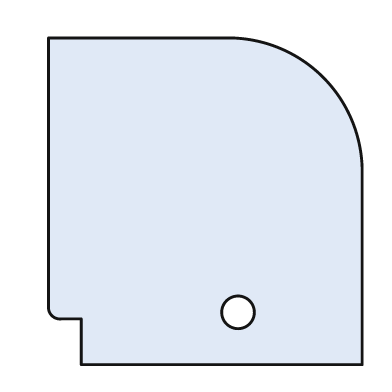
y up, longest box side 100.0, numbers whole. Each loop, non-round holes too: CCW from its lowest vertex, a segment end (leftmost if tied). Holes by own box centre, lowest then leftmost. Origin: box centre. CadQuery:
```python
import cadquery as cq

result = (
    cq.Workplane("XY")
    .moveTo(-38.0, -50.0)
    .lineTo(48.0, -50.0)
    .lineTo(48.0, 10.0)
    .threePointArc((36.0, 38.0), (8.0, 50.0))
    .lineTo(-48.0, 50.0)
    .lineTo(-48.0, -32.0)
    .threePointArc((-47.0, -35.0), (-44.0, -36.0))
    .lineTo(-38.0, -36.0)
    .close()
    .moveTo(10.0, -34.0)
    .circle(5.0)
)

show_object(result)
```